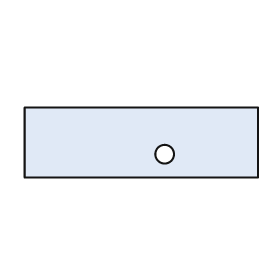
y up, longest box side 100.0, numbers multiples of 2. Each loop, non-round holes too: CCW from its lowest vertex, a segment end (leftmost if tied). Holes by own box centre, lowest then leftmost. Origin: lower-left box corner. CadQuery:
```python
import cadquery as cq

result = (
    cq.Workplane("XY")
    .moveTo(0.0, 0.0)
    .lineTo(100.0, 0.0)
    .lineTo(100.0, 30.0)
    .lineTo(0.0, 30.0)
    .close()
    .moveTo(60.0, 10.0)
    .circle(4.0)
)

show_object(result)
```